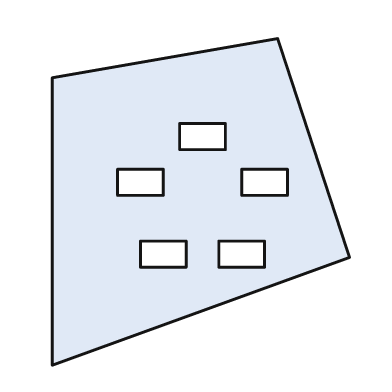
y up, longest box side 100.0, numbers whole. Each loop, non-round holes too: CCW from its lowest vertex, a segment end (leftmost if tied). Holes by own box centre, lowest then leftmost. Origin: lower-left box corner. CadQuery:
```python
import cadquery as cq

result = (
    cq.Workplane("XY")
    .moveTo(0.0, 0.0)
    .lineTo(91.0, 33.0)
    .lineTo(69.0, 100.0)
    .lineTo(0.0, 88.0)
    .close()
    .moveTo(27.0, 30.0)
    .lineTo(41.0, 30.0)
    .lineTo(41.0, 38.0)
    .lineTo(27.0, 38.0)
    .close()
    .moveTo(51.0, 30.0)
    .lineTo(65.0, 30.0)
    .lineTo(65.0, 38.0)
    .lineTo(51.0, 38.0)
    .close()
    .moveTo(20.0, 52.0)
    .lineTo(34.0, 52.0)
    .lineTo(34.0, 60.0)
    .lineTo(20.0, 60.0)
    .close()
    .moveTo(58.0, 52.0)
    .lineTo(72.0, 52.0)
    .lineTo(72.0, 60.0)
    .lineTo(58.0, 60.0)
    .close()
    .moveTo(39.0, 66.0)
    .lineTo(53.0, 66.0)
    .lineTo(53.0, 74.0)
    .lineTo(39.0, 74.0)
    .close()
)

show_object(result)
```